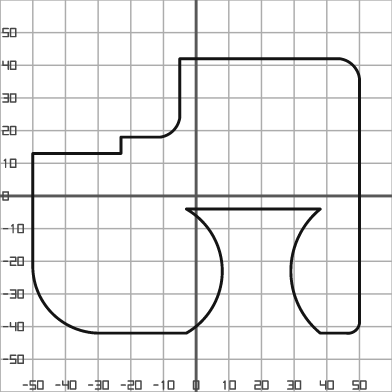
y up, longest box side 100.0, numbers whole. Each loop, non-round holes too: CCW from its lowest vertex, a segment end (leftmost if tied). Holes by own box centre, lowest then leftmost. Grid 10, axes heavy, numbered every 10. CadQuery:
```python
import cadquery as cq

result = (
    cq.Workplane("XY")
    .moveTo(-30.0, -42.0)
    .lineTo(-3.0, -42.0)
    .threePointArc((8.0, -23.0), (-3.0, -4.0))
    .lineTo(38.0, -4.0)
    .threePointArc((29.0, -23.0), (38.0, -42.0))
    .lineTo(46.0, -42.0)
    .threePointArc((49.0, -41.0), (50.0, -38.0))
    .lineTo(50.0, 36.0)
    .threePointArc((48.0, 40.0), (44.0, 42.0))
    .lineTo(-5.0, 42.0)
    .lineTo(-5.0, 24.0)
    .threePointArc((-7.0, 20.0), (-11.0, 18.0))
    .lineTo(-23.0, 18.0)
    .lineTo(-23.0, 13.0)
    .lineTo(-50.0, 13.0)
    .lineTo(-50.0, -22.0)
    .threePointArc((-44.0, -36.0), (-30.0, -42.0))
    .close()
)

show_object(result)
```